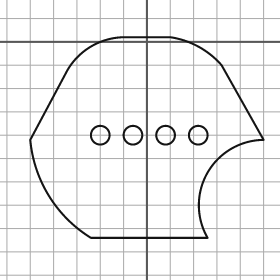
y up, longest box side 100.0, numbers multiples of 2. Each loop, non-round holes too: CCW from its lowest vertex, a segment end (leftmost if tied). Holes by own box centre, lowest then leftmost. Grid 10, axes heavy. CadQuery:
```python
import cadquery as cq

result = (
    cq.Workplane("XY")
    .moveTo(-24.0, -84.0)
    .lineTo(26.0, -84.0)
    .threePointArc((26.0, -56.0), (50.0, -42.0))
    .lineTo(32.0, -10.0)
    .threePointArc((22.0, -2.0), (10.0, 2.0))
    .lineTo(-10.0, 2.0)
    .threePointArc((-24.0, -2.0), (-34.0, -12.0))
    .lineTo(-50.0, -42.0)
    .threePointArc((-42.0, -66.0), (-24.0, -84.0))
    .close()
    .moveTo(-20.0, -40.0)
    .circle(4.0)
    .moveTo(-6.0, -40.0)
    .circle(4.0)
    .moveTo(8.0, -40.0)
    .circle(4.0)
    .moveTo(22.0, -40.0)
    .circle(4.0)
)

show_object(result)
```